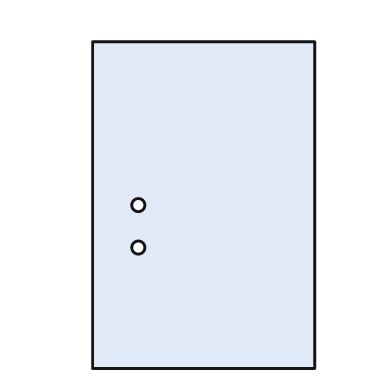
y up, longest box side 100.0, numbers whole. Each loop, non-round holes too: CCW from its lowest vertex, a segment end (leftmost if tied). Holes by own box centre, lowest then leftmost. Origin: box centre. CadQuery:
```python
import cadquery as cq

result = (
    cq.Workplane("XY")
    .moveTo(-34.0, -50.0)
    .lineTo(34.0, -50.0)
    .lineTo(34.0, 50.0)
    .lineTo(-34.0, 50.0)
    .close()
    .moveTo(-20.0, -13.0)
    .circle(2.0)
    .moveTo(-20.0, 0.0)
    .circle(2.0)
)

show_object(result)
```